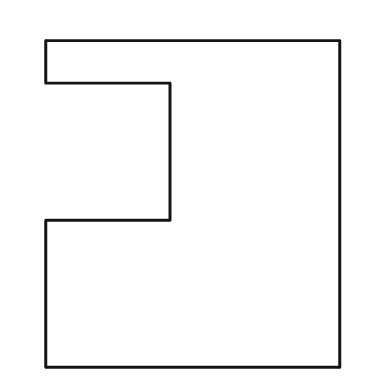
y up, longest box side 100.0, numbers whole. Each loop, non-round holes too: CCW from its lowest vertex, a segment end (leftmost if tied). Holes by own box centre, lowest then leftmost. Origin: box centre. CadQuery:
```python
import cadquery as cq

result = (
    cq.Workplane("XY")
    .moveTo(-45.0, -50.0)
    .lineTo(45.0, -50.0)
    .lineTo(45.0, 50.0)
    .lineTo(-45.0, 50.0)
    .lineTo(-45.0, 37.0)
    .lineTo(-7.0, 37.0)
    .lineTo(-7.0, -5.0)
    .lineTo(-45.0, -5.0)
    .close()
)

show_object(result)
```